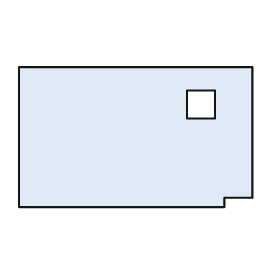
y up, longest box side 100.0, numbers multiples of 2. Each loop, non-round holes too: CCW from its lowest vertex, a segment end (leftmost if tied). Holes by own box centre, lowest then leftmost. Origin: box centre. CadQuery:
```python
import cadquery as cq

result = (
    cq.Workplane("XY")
    .moveTo(-50.0, -30.0)
    .lineTo(38.0, -30.0)
    .lineTo(38.0, -26.0)
    .lineTo(50.0, -26.0)
    .lineTo(50.0, 30.0)
    .lineTo(-50.0, 30.0)
    .close()
    .moveTo(22.0, 8.0)
    .lineTo(34.0, 8.0)
    .lineTo(34.0, 20.0)
    .lineTo(22.0, 20.0)
    .close()
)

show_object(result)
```